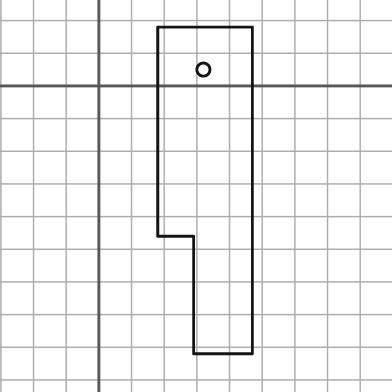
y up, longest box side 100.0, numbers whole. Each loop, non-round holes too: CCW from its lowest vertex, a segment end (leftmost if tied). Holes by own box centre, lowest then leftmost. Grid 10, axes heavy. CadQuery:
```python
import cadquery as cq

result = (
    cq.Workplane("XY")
    .moveTo(29.0, -82.0)
    .lineTo(47.0, -82.0)
    .lineTo(47.0, 18.0)
    .lineTo(18.0, 18.0)
    .lineTo(18.0, -46.0)
    .lineTo(29.0, -46.0)
    .close()
    .moveTo(32.0, 5.0)
    .circle(2.0)
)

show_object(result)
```